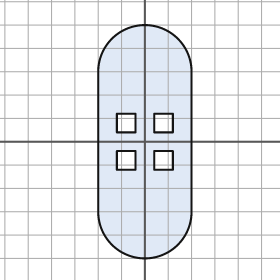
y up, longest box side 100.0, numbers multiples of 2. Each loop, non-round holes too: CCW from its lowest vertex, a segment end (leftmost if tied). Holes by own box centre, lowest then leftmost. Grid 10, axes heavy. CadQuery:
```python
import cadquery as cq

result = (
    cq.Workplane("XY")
    .moveTo(-20.0, -30.0)
    .threePointArc((0.0, -50.0), (20.0, -30.0))
    .lineTo(20.0, 30.0)
    .threePointArc((0.0, 50.0), (-20.0, 30.0))
    .close()
    .moveTo(-12.0, -12.0)
    .lineTo(-4.0, -12.0)
    .lineTo(-4.0, -4.0)
    .lineTo(-12.0, -4.0)
    .close()
    .moveTo(4.0, -12.0)
    .lineTo(12.0, -12.0)
    .lineTo(12.0, -4.0)
    .lineTo(4.0, -4.0)
    .close()
    .moveTo(-12.0, 4.0)
    .lineTo(-4.0, 4.0)
    .lineTo(-4.0, 12.0)
    .lineTo(-12.0, 12.0)
    .close()
    .moveTo(4.0, 4.0)
    .lineTo(12.0, 4.0)
    .lineTo(12.0, 12.0)
    .lineTo(4.0, 12.0)
    .close()
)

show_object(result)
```